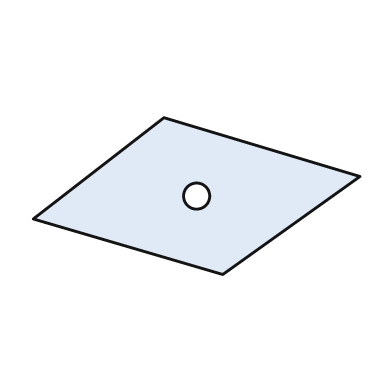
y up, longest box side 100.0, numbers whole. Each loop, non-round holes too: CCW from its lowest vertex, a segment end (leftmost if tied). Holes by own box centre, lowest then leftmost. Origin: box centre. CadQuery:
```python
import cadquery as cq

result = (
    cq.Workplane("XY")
    .moveTo(8.0, -24.0)
    .lineTo(50.0, 6.0)
    .lineTo(-10.0, 24.0)
    .lineTo(-50.0, -7.0)
    .close()
    .moveTo(0.0, 0.0)
    .circle(4.0)
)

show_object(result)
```